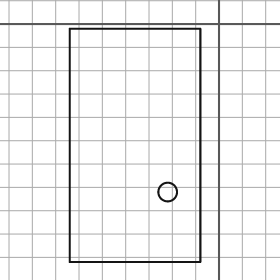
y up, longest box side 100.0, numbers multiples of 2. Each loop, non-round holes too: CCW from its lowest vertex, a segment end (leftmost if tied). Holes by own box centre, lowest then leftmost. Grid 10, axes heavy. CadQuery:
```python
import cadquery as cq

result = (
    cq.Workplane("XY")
    .moveTo(-64.0, -102.0)
    .lineTo(-8.0, -102.0)
    .lineTo(-8.0, -2.0)
    .lineTo(-64.0, -2.0)
    .close()
    .moveTo(-22.0, -72.0)
    .circle(4.0)
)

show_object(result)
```